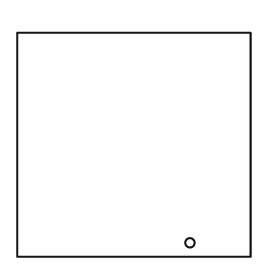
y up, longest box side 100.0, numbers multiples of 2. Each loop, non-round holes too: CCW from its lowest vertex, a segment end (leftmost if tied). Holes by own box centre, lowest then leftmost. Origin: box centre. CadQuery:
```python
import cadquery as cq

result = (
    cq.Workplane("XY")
    .moveTo(-50.0, -48.0)
    .lineTo(50.0, -48.0)
    .lineTo(50.0, 48.0)
    .lineTo(-50.0, 48.0)
    .close()
    .moveTo(24.0, -42.0)
    .circle(2.0)
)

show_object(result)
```